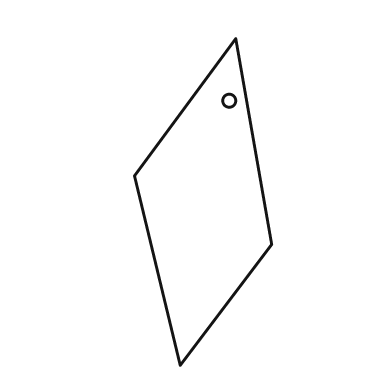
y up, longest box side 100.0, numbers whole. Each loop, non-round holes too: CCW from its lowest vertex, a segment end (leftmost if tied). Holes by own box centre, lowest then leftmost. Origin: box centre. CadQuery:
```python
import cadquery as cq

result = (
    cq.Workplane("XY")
    .moveTo(-7.0, -50.0)
    .lineTo(21.0, -13.0)
    .lineTo(10.0, 50.0)
    .lineTo(-21.0, 8.0)
    .close()
    .moveTo(8.0, 31.0)
    .circle(2.0)
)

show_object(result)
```